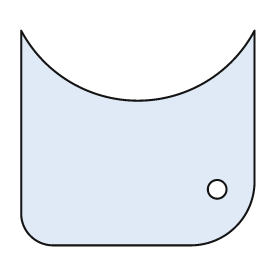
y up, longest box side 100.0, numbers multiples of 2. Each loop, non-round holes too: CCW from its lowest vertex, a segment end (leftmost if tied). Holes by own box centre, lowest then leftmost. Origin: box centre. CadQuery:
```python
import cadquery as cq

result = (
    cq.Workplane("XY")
    .moveTo(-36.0, -46.0)
    .lineTo(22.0, -46.0)
    .threePointArc((42.0, -38.0), (50.0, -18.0))
    .lineTo(50.0, 46.0)
    .threePointArc((0.0, 16.0), (-50.0, 46.0))
    .lineTo(-50.0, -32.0)
    .threePointArc((-46.0, -42.0), (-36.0, -46.0))
    .close()
    .moveTo(34.0, -22.0)
    .circle(4.0)
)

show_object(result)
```